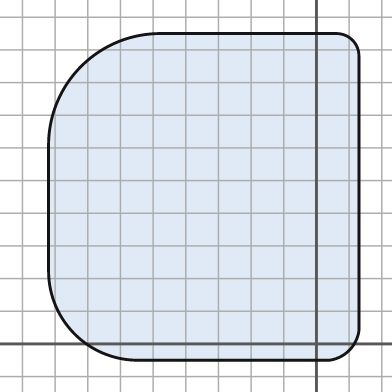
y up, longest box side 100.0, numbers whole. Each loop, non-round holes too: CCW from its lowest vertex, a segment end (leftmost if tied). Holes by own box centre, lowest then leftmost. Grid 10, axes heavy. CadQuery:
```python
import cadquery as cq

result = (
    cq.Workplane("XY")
    .moveTo(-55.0, -5.0)
    .lineTo(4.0, -5.0)
    .threePointArc((10.0, -2.0), (13.0, 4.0))
    .lineTo(13.0, 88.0)
    .threePointArc((11.0, 93.0), (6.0, 95.0))
    .lineTo(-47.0, 95.0)
    .threePointArc((-72.0, 85.0), (-82.0, 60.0))
    .lineTo(-82.0, 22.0)
    .threePointArc((-74.0, 3.0), (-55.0, -5.0))
    .close()
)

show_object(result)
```